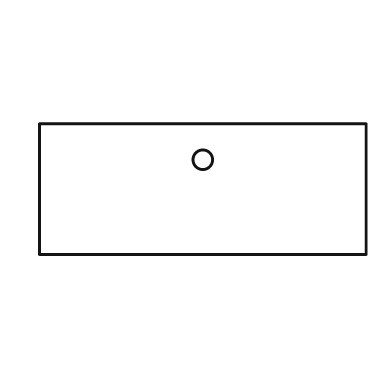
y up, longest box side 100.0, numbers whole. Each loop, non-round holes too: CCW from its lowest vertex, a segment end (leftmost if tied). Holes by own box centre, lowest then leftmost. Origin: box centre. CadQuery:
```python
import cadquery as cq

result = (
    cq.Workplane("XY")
    .moveTo(-50.0, -20.0)
    .lineTo(50.0, -20.0)
    .lineTo(50.0, 20.0)
    .lineTo(-50.0, 20.0)
    .close()
    .moveTo(0.0, 9.0)
    .circle(3.0)
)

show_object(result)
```